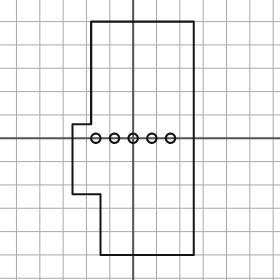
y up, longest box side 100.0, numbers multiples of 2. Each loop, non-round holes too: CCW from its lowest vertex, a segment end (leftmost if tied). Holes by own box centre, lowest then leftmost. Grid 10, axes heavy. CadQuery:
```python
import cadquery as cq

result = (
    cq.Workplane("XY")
    .moveTo(-14.0, -50.0)
    .lineTo(26.0, -50.0)
    .lineTo(26.0, 50.0)
    .lineTo(-18.0, 50.0)
    .lineTo(-18.0, 6.0)
    .lineTo(-26.0, 6.0)
    .lineTo(-26.0, -24.0)
    .lineTo(-14.0, -24.0)
    .close()
    .moveTo(-16.0, 0.0)
    .circle(2.0)
    .moveTo(-8.0, 0.0)
    .circle(2.0)
    .moveTo(0.0, 0.0)
    .circle(2.0)
    .moveTo(8.0, 0.0)
    .circle(2.0)
    .moveTo(16.0, 0.0)
    .circle(2.0)
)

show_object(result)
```